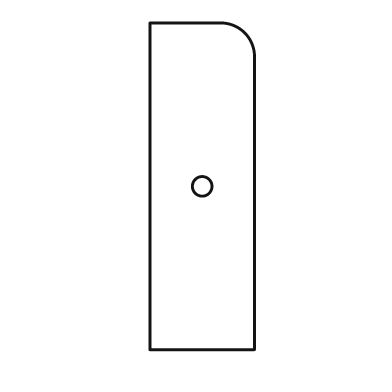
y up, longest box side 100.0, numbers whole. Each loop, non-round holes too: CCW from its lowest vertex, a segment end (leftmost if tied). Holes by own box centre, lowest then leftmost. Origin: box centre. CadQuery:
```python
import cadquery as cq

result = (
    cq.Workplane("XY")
    .moveTo(-16.0, -50.0)
    .lineTo(16.0, -50.0)
    .lineTo(16.0, 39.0)
    .threePointArc((13.0, 47.0), (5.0, 50.0))
    .lineTo(-16.0, 50.0)
    .close()
    .moveTo(0.0, 0.0)
    .circle(3.0)
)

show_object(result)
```